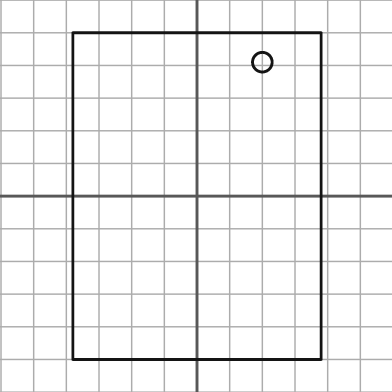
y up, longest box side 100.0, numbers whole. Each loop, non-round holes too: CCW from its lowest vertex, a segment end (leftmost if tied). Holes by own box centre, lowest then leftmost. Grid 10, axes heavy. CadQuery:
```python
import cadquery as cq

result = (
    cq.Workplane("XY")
    .moveTo(-38.0, -50.0)
    .lineTo(38.0, -50.0)
    .lineTo(38.0, 50.0)
    .lineTo(-38.0, 50.0)
    .close()
    .moveTo(20.0, 41.0)
    .circle(3.0)
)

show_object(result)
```